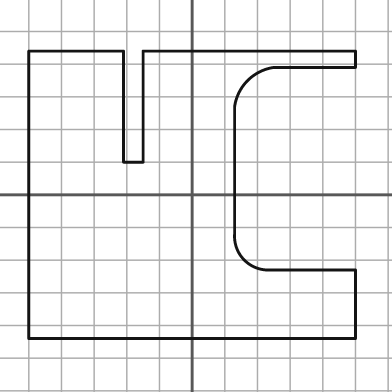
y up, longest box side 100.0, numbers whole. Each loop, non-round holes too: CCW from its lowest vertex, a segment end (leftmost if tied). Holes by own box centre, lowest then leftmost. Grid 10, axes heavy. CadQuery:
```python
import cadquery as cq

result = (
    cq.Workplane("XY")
    .moveTo(-50.0, -44.0)
    .lineTo(50.0, -44.0)
    .lineTo(50.0, -23.0)
    .lineTo(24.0, -23.0)
    .threePointArc((16.0, -20.0), (13.0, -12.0))
    .lineTo(13.0, 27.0)
    .threePointArc((17.0, 35.0), (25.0, 39.0))
    .lineTo(50.0, 39.0)
    .lineTo(50.0, 44.0)
    .lineTo(-15.0, 44.0)
    .lineTo(-15.0, 10.0)
    .lineTo(-21.0, 10.0)
    .lineTo(-21.0, 44.0)
    .lineTo(-50.0, 44.0)
    .close()
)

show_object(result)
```